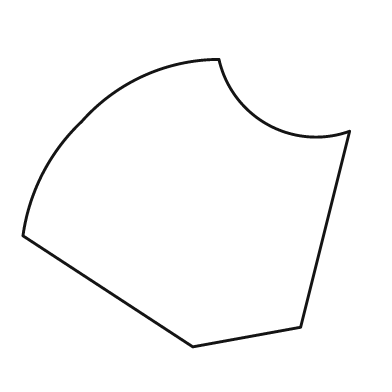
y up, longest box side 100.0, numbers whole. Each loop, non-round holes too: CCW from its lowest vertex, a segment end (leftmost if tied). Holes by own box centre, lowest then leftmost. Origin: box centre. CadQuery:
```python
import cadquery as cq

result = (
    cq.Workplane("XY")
    .moveTo(2.0, -44.0)
    .lineTo(35.0, -38.0)
    .lineTo(50.0, 22.0)
    .threePointArc((25.0, 24.0), (10.0, 44.0))
    .threePointArc((-13.0, 39.0), (-32.0, 25.0))
    .threePointArc((-44.0, 9.0), (-50.0, -10.0))
    .close()
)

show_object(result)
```